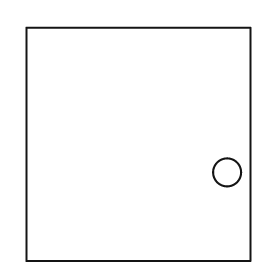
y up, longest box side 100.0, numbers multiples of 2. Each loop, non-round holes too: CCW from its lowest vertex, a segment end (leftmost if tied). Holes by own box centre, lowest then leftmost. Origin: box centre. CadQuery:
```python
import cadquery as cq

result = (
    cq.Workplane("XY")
    .moveTo(-48.0, -50.0)
    .lineTo(48.0, -50.0)
    .lineTo(48.0, 50.0)
    .lineTo(-48.0, 50.0)
    .close()
    .moveTo(38.0, -12.0)
    .circle(6.0)
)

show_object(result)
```